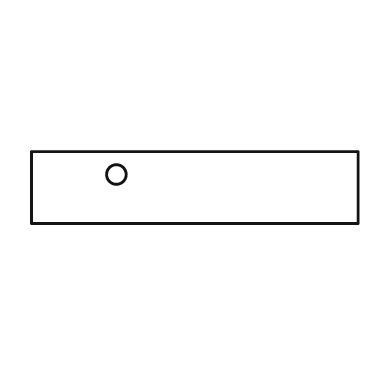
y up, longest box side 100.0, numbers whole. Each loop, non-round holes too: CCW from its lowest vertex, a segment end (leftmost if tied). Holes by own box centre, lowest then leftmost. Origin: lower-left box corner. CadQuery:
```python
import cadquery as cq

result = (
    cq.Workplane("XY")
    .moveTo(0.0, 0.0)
    .lineTo(100.0, 0.0)
    .lineTo(100.0, 22.0)
    .lineTo(0.0, 22.0)
    .close()
    .moveTo(26.0, 15.0)
    .circle(3.0)
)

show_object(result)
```